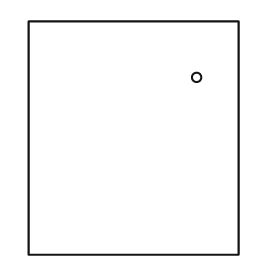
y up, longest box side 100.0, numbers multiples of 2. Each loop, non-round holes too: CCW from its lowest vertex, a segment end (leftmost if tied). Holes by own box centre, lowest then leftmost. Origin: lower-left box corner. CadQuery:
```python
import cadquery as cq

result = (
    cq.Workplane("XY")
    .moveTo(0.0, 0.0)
    .lineTo(90.0, 0.0)
    .lineTo(90.0, 100.0)
    .lineTo(0.0, 100.0)
    .close()
    .moveTo(72.0, 76.0)
    .circle(2.0)
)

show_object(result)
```